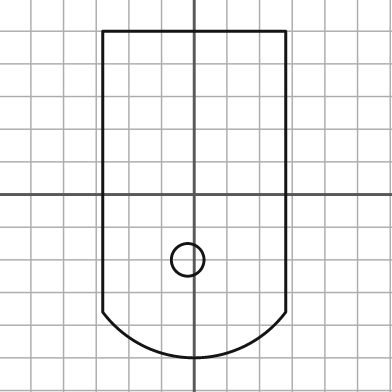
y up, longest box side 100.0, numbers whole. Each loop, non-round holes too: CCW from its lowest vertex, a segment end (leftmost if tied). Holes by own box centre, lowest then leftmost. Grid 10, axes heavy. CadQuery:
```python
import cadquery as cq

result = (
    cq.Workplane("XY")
    .moveTo(-28.0, -36.0)
    .threePointArc((0.0, -50.0), (28.0, -36.0))
    .lineTo(28.0, 50.0)
    .lineTo(-28.0, 50.0)
    .close()
    .moveTo(-2.0, -20.0)
    .circle(5.0)
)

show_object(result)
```